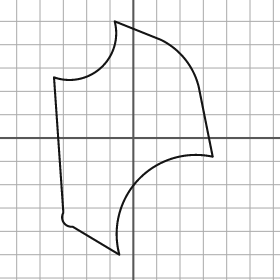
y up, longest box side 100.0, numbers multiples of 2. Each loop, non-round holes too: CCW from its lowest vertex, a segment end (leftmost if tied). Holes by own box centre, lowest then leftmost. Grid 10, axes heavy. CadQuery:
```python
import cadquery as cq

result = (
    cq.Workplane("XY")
    .moveTo(-6.0, -50.0)
    .threePointArc((2.0, -18.0), (34.0, -8.0))
    .lineTo(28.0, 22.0)
    .threePointArc((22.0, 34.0), (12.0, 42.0))
    .lineTo(-8.0, 50.0)
    .threePointArc((-14.0, 30.0), (-34.0, 26.0))
    .lineTo(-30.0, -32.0)
    .threePointArc((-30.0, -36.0), (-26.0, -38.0))
    .close()
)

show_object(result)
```